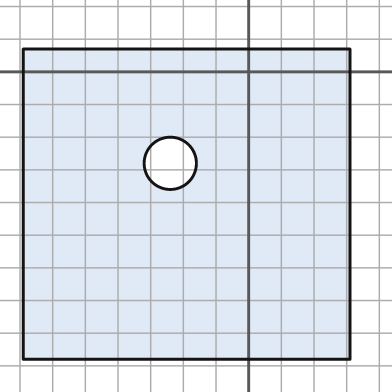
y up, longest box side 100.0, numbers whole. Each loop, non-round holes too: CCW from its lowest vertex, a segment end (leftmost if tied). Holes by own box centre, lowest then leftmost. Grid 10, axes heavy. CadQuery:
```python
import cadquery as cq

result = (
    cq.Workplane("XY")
    .moveTo(-69.0, -88.0)
    .lineTo(31.0, -88.0)
    .lineTo(31.0, 7.0)
    .lineTo(-69.0, 7.0)
    .close()
    .moveTo(-24.0, -28.0)
    .circle(8.0)
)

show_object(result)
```